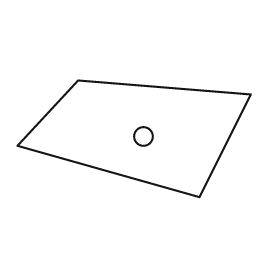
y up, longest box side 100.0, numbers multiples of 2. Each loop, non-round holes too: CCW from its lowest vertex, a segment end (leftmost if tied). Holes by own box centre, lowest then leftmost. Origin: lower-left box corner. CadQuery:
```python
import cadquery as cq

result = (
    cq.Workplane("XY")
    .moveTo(78.0, 0.0)
    .lineTo(100.0, 44.0)
    .lineTo(26.0, 50.0)
    .lineTo(0.0, 22.0)
    .close()
    .moveTo(54.0, 26.0)
    .circle(4.0)
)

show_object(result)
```